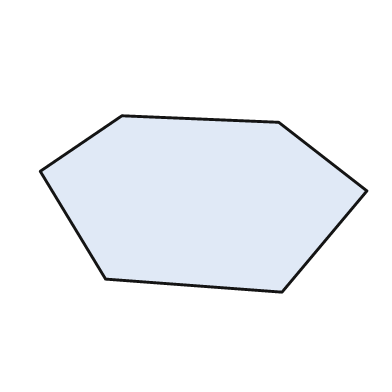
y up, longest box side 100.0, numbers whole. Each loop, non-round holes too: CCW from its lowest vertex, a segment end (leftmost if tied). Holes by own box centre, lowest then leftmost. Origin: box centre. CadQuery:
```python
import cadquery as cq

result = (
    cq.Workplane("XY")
    .moveTo(24.0, -27.0)
    .lineTo(50.0, 4.0)
    .lineTo(23.0, 25.0)
    .lineTo(-25.0, 27.0)
    .lineTo(-50.0, 10.0)
    .lineTo(-30.0, -23.0)
    .close()
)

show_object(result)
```